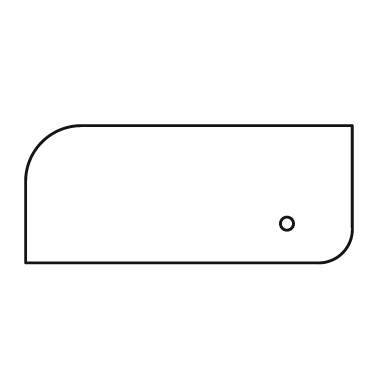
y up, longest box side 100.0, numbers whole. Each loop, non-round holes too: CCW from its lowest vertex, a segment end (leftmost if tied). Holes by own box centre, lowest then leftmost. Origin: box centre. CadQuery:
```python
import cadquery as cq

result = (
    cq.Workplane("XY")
    .moveTo(-50.0, -21.0)
    .lineTo(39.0, -21.0)
    .threePointArc((47.0, -18.0), (50.0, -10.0))
    .lineTo(50.0, 21.0)
    .lineTo(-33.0, 21.0)
    .threePointArc((-45.0, 16.0), (-50.0, 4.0))
    .close()
    .moveTo(30.0, -9.0)
    .circle(2.0)
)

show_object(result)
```